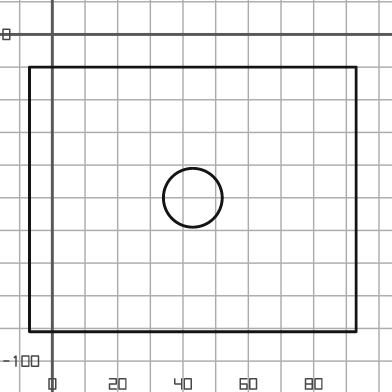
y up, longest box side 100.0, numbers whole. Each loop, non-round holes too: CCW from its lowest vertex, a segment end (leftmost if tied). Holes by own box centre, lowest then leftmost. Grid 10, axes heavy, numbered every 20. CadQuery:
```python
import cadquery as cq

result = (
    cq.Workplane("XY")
    .moveTo(-7.0, -91.0)
    .lineTo(93.0, -91.0)
    .lineTo(93.0, -10.0)
    .lineTo(-7.0, -10.0)
    .close()
    .moveTo(43.0, -50.0)
    .circle(9.0)
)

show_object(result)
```